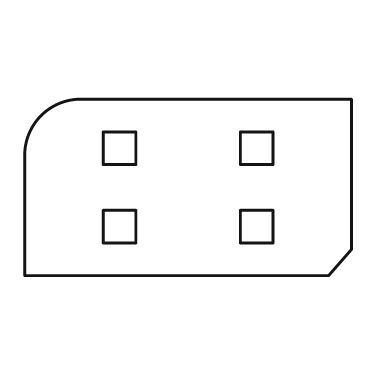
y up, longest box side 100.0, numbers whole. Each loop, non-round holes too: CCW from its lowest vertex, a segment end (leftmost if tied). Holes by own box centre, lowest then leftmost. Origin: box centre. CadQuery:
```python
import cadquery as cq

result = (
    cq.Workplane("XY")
    .moveTo(-50.0, -27.0)
    .lineTo(43.0, -27.0)
    .lineTo(50.0, -19.0)
    .lineTo(50.0, 27.0)
    .lineTo(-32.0, 27.0)
    .threePointArc((-45.0, 22.0), (-50.0, 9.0))
    .close()
    .moveTo(-26.0, -17.0)
    .lineTo(-16.0, -17.0)
    .lineTo(-16.0, -7.0)
    .lineTo(-26.0, -7.0)
    .close()
    .moveTo(16.0, -17.0)
    .lineTo(26.0, -17.0)
    .lineTo(26.0, -7.0)
    .lineTo(16.0, -7.0)
    .close()
    .moveTo(-26.0, 7.0)
    .lineTo(-16.0, 7.0)
    .lineTo(-16.0, 17.0)
    .lineTo(-26.0, 17.0)
    .close()
    .moveTo(16.0, 7.0)
    .lineTo(26.0, 7.0)
    .lineTo(26.0, 17.0)
    .lineTo(16.0, 17.0)
    .close()
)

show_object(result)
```